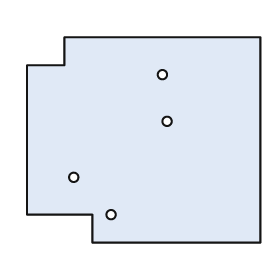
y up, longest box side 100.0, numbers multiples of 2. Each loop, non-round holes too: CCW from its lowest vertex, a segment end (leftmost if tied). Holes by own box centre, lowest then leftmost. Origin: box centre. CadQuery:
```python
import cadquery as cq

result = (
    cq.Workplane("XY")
    .moveTo(-22.0, -44.0)
    .lineTo(50.0, -44.0)
    .lineTo(50.0, 44.0)
    .lineTo(-34.0, 44.0)
    .lineTo(-34.0, 32.0)
    .lineTo(-50.0, 32.0)
    .lineTo(-50.0, -32.0)
    .lineTo(-22.0, -32.0)
    .close()
    .moveTo(-14.0, -32.0)
    .circle(2.0)
    .moveTo(-30.0, -16.0)
    .circle(2.0)
    .moveTo(10.0, 8.0)
    .circle(2.0)
    .moveTo(8.0, 28.0)
    .circle(2.0)
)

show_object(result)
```